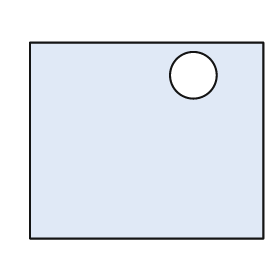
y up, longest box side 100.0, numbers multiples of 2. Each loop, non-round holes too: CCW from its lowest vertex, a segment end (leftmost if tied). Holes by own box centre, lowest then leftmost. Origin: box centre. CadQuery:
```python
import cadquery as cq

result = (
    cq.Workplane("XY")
    .moveTo(-50.0, -42.0)
    .lineTo(50.0, -42.0)
    .lineTo(50.0, 42.0)
    .lineTo(-50.0, 42.0)
    .close()
    .moveTo(20.0, 28.0)
    .circle(10.0)
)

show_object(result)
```